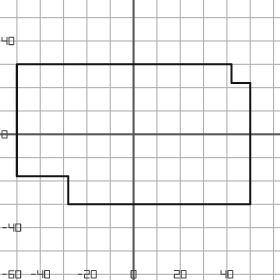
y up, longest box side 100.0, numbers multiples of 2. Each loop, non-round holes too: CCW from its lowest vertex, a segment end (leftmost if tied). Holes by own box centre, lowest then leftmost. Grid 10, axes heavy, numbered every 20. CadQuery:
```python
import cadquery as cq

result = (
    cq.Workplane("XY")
    .moveTo(-28.0, -30.0)
    .lineTo(50.0, -30.0)
    .lineTo(50.0, 22.0)
    .lineTo(42.0, 22.0)
    .lineTo(42.0, 30.0)
    .lineTo(-50.0, 30.0)
    .lineTo(-50.0, -18.0)
    .lineTo(-28.0, -18.0)
    .close()
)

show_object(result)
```